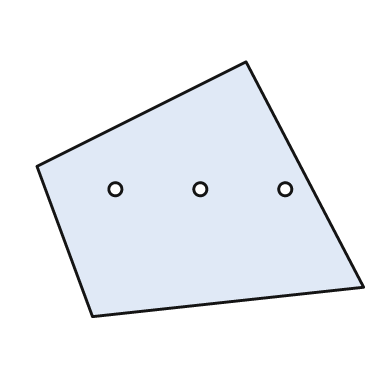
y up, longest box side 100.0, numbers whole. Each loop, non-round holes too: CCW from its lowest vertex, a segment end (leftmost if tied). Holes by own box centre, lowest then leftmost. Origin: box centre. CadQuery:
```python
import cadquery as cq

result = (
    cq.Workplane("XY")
    .moveTo(-33.0, -39.0)
    .lineTo(50.0, -30.0)
    .lineTo(14.0, 39.0)
    .lineTo(-50.0, 7.0)
    .close()
    .moveTo(-26.0, 0.0)
    .circle(2.0)
    .moveTo(0.0, 0.0)
    .circle(2.0)
    .moveTo(26.0, 0.0)
    .circle(2.0)
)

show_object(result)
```